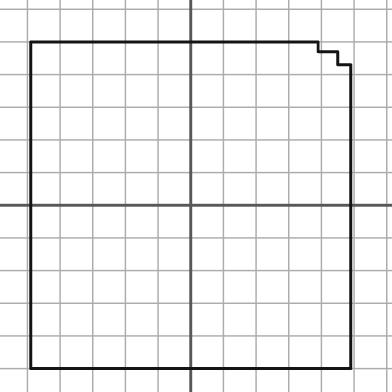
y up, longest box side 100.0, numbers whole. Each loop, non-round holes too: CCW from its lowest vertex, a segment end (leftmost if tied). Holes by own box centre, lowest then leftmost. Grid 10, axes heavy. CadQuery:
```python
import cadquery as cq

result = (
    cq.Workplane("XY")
    .moveTo(-49.0, -50.0)
    .lineTo(49.0, -50.0)
    .lineTo(49.0, 43.0)
    .lineTo(45.0, 43.0)
    .lineTo(45.0, 47.0)
    .lineTo(39.0, 47.0)
    .lineTo(39.0, 50.0)
    .lineTo(-49.0, 50.0)
    .close()
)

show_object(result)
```